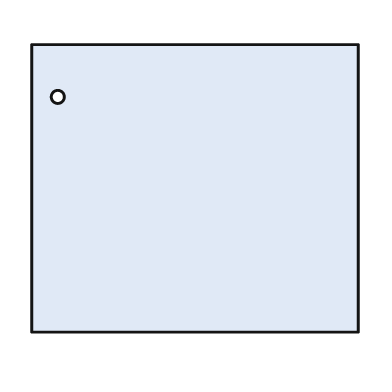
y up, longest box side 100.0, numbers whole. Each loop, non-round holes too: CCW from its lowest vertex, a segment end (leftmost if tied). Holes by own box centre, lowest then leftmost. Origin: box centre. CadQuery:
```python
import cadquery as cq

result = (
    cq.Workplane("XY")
    .moveTo(-50.0, -44.0)
    .lineTo(50.0, -44.0)
    .lineTo(50.0, 44.0)
    .lineTo(-50.0, 44.0)
    .close()
    .moveTo(-42.0, 28.0)
    .circle(2.0)
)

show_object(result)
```